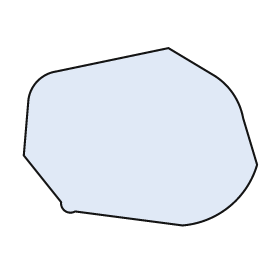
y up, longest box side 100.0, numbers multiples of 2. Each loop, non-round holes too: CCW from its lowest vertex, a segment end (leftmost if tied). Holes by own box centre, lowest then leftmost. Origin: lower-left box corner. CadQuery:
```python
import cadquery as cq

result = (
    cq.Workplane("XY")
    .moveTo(68.0, 0.0)
    .threePointArc((88.0, 8.0), (100.0, 26.0))
    .lineTo(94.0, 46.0)
    .threePointArc((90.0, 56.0), (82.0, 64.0))
    .lineTo(62.0, 76.0)
    .lineTo(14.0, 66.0)
    .threePointArc((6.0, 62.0), (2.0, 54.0))
    .lineTo(0.0, 30.0)
    .lineTo(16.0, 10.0)
    .threePointArc((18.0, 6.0), (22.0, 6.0))
    .close()
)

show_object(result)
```